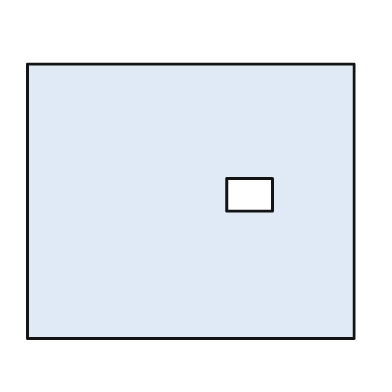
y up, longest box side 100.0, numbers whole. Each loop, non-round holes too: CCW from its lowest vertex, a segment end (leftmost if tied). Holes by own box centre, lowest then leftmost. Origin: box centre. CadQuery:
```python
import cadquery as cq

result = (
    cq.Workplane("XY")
    .moveTo(-50.0, -42.0)
    .lineTo(50.0, -42.0)
    .lineTo(50.0, 42.0)
    .lineTo(-50.0, 42.0)
    .close()
    .moveTo(11.0, -3.0)
    .lineTo(25.0, -3.0)
    .lineTo(25.0, 7.0)
    .lineTo(11.0, 7.0)
    .close()
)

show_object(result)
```